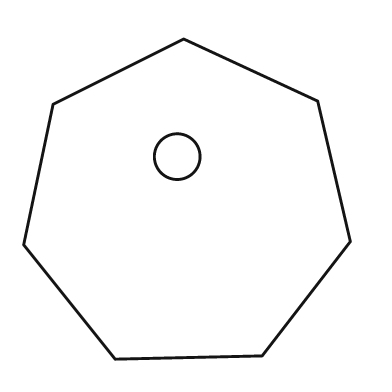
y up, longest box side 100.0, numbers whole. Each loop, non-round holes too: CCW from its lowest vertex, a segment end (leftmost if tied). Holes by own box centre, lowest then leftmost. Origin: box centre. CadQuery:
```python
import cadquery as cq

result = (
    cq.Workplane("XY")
    .moveTo(-22.0, -49.0)
    .lineTo(23.0, -48.0)
    .lineTo(50.0, -13.0)
    .lineTo(40.0, 30.0)
    .lineTo(-1.0, 49.0)
    .lineTo(-41.0, 29.0)
    .lineTo(-50.0, -14.0)
    .close()
    .moveTo(-3.0, 13.0)
    .circle(7.0)
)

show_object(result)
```